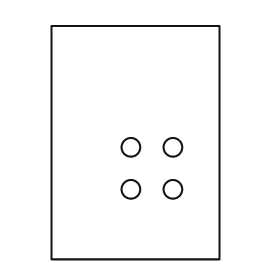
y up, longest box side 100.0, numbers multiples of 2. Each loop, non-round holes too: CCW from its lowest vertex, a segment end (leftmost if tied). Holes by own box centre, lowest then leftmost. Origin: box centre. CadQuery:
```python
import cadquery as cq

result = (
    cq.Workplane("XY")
    .moveTo(-36.0, -50.0)
    .lineTo(36.0, -50.0)
    .lineTo(36.0, 50.0)
    .lineTo(-36.0, 50.0)
    .close()
    .moveTo(-2.0, -20.0)
    .circle(4.0)
    .moveTo(16.0, -20.0)
    .circle(4.0)
    .moveTo(-2.0, -2.0)
    .circle(4.0)
    .moveTo(16.0, -2.0)
    .circle(4.0)
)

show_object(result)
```